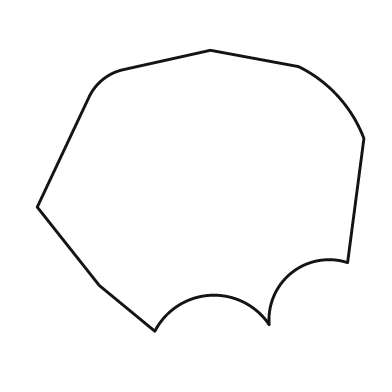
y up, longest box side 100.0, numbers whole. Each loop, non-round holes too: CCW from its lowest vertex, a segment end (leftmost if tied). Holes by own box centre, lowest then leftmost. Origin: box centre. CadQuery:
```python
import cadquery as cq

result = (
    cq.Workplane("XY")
    .moveTo(-14.0, -43.0)
    .threePointArc((3.0, -32.0), (21.0, -41.0))
    .threePointArc((28.0, -25.0), (45.0, -22.0))
    .lineTo(50.0, 16.0)
    .threePointArc((42.0, 29.0), (30.0, 38.0))
    .lineTo(3.0, 43.0)
    .lineTo(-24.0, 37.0)
    .threePointArc((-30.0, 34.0), (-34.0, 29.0))
    .lineTo(-50.0, -5.0)
    .lineTo(-31.0, -29.0)
    .close()
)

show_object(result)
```